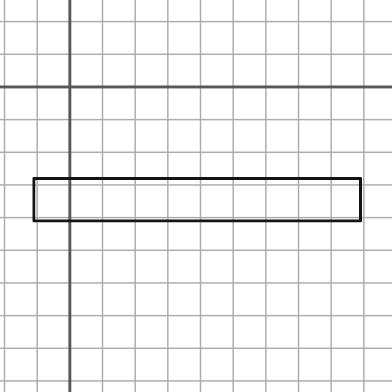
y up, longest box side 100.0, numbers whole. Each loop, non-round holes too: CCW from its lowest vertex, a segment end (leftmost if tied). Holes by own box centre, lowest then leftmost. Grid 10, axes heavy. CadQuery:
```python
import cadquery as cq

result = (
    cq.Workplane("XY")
    .moveTo(-11.0, -41.0)
    .lineTo(89.0, -41.0)
    .lineTo(89.0, -28.0)
    .lineTo(-11.0, -28.0)
    .close()
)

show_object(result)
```